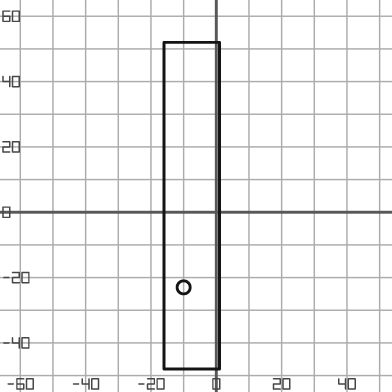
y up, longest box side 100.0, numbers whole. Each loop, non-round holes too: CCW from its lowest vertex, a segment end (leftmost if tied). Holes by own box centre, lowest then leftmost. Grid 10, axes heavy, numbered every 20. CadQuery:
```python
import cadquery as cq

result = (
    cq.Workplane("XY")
    .moveTo(-16.0, -48.0)
    .lineTo(1.0, -48.0)
    .lineTo(1.0, 52.0)
    .lineTo(-16.0, 52.0)
    .close()
    .moveTo(-10.0, -23.0)
    .circle(2.0)
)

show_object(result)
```